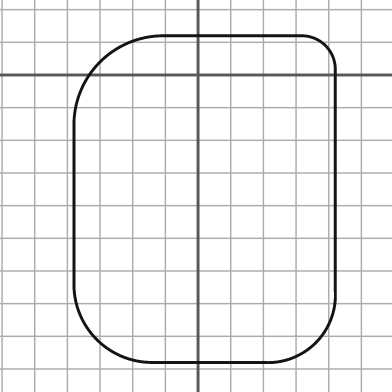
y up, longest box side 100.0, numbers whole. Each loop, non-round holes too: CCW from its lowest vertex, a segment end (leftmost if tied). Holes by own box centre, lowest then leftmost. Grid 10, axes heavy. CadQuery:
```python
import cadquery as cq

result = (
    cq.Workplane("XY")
    .moveTo(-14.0, -88.0)
    .lineTo(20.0, -88.0)
    .threePointArc((36.0, -82.0), (42.0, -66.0))
    .lineTo(42.0, 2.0)
    .threePointArc((39.0, 9.0), (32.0, 12.0))
    .lineTo(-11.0, 12.0)
    .threePointArc((-30.0, 4.0), (-38.0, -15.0))
    .lineTo(-38.0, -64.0)
    .threePointArc((-31.0, -81.0), (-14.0, -88.0))
    .close()
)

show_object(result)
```